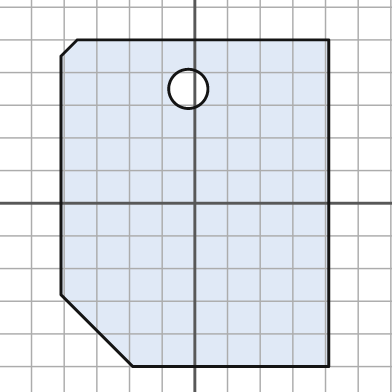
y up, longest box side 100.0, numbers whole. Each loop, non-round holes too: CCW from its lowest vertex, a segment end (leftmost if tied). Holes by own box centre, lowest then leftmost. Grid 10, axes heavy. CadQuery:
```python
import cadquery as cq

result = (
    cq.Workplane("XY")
    .moveTo(-19.0, -50.0)
    .lineTo(41.0, -50.0)
    .lineTo(41.0, 50.0)
    .lineTo(-36.0, 50.0)
    .lineTo(-41.0, 45.0)
    .lineTo(-41.0, -28.0)
    .close()
    .moveTo(-2.0, 35.0)
    .circle(6.0)
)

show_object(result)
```